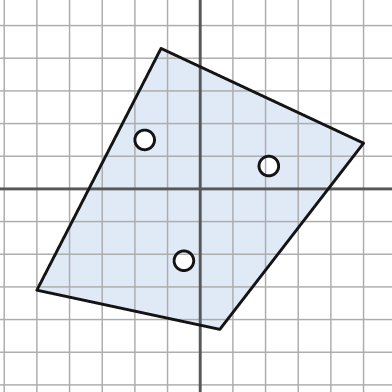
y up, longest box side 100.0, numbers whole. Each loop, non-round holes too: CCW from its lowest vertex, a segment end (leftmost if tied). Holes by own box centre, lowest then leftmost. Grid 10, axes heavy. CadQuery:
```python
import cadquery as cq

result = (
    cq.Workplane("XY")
    .moveTo(6.0, -43.0)
    .lineTo(50.0, 14.0)
    .lineTo(-12.0, 43.0)
    .lineTo(-50.0, -31.0)
    .close()
    .moveTo(-5.0, -22.0)
    .circle(3.0)
    .moveTo(21.0, 7.0)
    .circle(3.0)
    .moveTo(-17.0, 15.0)
    .circle(3.0)
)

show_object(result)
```